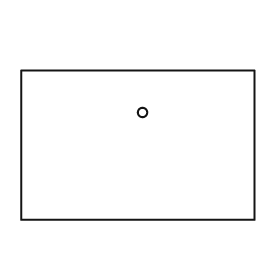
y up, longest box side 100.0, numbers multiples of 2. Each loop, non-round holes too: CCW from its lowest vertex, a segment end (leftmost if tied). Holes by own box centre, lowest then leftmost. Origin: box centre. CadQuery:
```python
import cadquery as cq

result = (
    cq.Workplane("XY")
    .moveTo(-50.0, -32.0)
    .lineTo(50.0, -32.0)
    .lineTo(50.0, 32.0)
    .lineTo(-50.0, 32.0)
    .close()
    .moveTo(2.0, 14.0)
    .circle(2.0)
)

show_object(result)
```